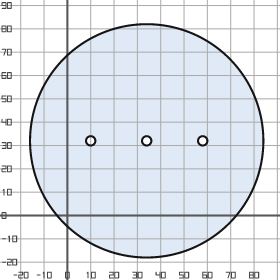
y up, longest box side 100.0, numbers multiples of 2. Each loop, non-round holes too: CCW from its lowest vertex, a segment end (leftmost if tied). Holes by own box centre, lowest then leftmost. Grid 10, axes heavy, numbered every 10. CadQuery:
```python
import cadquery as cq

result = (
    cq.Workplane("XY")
    .moveTo(34.0, 32.0)
    .circle(50.0)
    .moveTo(10.0, 32.0)
    .circle(2.0)
    .moveTo(34.0, 32.0)
    .circle(2.0)
    .moveTo(58.0, 32.0)
    .circle(2.0)
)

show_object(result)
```